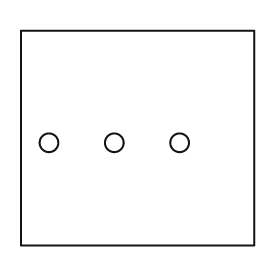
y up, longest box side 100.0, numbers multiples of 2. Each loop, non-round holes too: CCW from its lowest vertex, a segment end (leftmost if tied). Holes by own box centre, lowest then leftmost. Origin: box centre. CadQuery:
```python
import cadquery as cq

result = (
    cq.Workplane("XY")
    .moveTo(-50.0, -46.0)
    .lineTo(50.0, -46.0)
    .lineTo(50.0, 46.0)
    .lineTo(-50.0, 46.0)
    .close()
    .moveTo(-38.0, -2.0)
    .circle(4.0)
    .moveTo(-10.0, -2.0)
    .circle(4.0)
    .moveTo(18.0, -2.0)
    .circle(4.0)
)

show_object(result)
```